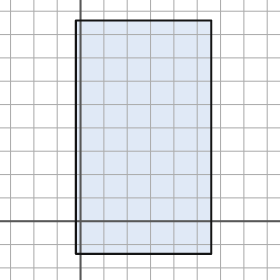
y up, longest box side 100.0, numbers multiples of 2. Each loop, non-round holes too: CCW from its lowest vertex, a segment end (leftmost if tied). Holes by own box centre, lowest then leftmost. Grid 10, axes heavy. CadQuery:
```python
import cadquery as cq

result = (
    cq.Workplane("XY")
    .moveTo(-2.0, -14.0)
    .lineTo(56.0, -14.0)
    .lineTo(56.0, 86.0)
    .lineTo(-2.0, 86.0)
    .close()
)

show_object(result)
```